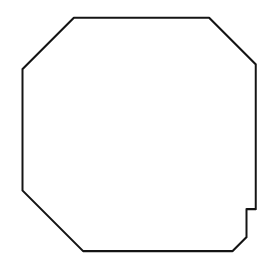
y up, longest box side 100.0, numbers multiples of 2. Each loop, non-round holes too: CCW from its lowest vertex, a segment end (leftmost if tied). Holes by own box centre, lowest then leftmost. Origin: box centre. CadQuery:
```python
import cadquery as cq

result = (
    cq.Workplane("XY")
    .moveTo(-24.0, -50.0)
    .lineTo(40.0, -50.0)
    .lineTo(46.0, -44.0)
    .lineTo(46.0, -32.0)
    .lineTo(50.0, -32.0)
    .lineTo(50.0, 30.0)
    .lineTo(30.0, 50.0)
    .lineTo(-28.0, 50.0)
    .lineTo(-50.0, 28.0)
    .lineTo(-50.0, -24.0)
    .close()
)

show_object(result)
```